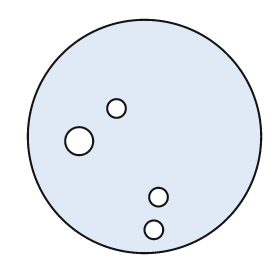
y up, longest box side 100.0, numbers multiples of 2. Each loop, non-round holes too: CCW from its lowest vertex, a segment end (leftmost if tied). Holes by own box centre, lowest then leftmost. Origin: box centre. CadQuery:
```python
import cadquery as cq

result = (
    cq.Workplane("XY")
    .moveTo(0.0, 0.0)
    .circle(50.0)
    .moveTo(4.0, -40.0)
    .circle(4.0)
    .moveTo(6.0, -26.0)
    .circle(4.0)
    .moveTo(-28.0, -2.0)
    .circle(6.0)
    .moveTo(-12.0, 12.0)
    .circle(4.0)
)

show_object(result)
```